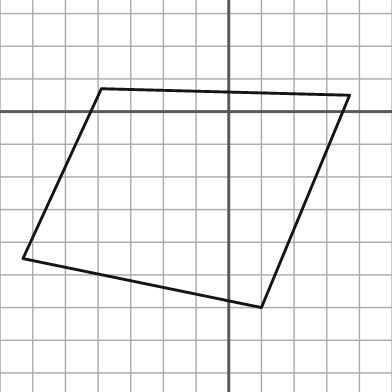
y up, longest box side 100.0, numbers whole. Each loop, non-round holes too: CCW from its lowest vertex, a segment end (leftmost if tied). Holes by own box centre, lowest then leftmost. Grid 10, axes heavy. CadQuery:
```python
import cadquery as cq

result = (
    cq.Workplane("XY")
    .moveTo(10.0, -60.0)
    .lineTo(37.0, 5.0)
    .lineTo(-39.0, 7.0)
    .lineTo(-63.0, -45.0)
    .close()
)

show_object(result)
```